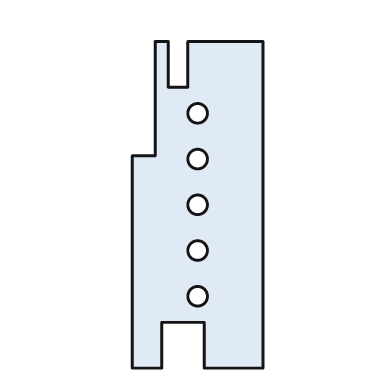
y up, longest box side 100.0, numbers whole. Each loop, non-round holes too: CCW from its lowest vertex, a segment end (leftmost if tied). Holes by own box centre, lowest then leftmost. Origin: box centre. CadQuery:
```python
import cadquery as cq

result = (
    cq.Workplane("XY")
    .moveTo(-20.0, -50.0)
    .lineTo(-11.0, -50.0)
    .lineTo(-11.0, -36.0)
    .lineTo(2.0, -36.0)
    .lineTo(2.0, -50.0)
    .lineTo(20.0, -50.0)
    .lineTo(20.0, 50.0)
    .lineTo(-3.0, 50.0)
    .lineTo(-3.0, 36.0)
    .lineTo(-9.0, 36.0)
    .lineTo(-9.0, 50.0)
    .lineTo(-13.0, 50.0)
    .lineTo(-13.0, 15.0)
    .lineTo(-20.0, 15.0)
    .close()
    .moveTo(0.0, -28.0)
    .circle(3.0)
    .moveTo(0.0, -14.0)
    .circle(3.0)
    .moveTo(0.0, 0.0)
    .circle(3.0)
    .moveTo(0.0, 14.0)
    .circle(3.0)
    .moveTo(0.0, 28.0)
    .circle(3.0)
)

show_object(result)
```